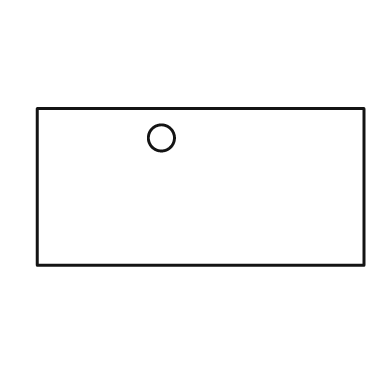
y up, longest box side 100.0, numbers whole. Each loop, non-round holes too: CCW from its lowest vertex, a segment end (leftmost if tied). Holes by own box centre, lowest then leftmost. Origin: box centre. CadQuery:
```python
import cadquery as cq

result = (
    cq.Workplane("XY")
    .moveTo(-50.0, -24.0)
    .lineTo(50.0, -24.0)
    .lineTo(50.0, 24.0)
    .lineTo(-50.0, 24.0)
    .close()
    .moveTo(-12.0, 15.0)
    .circle(4.0)
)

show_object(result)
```